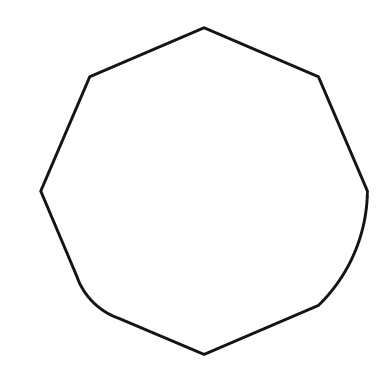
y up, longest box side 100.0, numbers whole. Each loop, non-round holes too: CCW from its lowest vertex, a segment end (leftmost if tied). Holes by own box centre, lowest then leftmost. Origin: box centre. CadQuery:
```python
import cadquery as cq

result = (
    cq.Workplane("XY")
    .moveTo(0.0, -50.0)
    .lineTo(35.0, -35.0)
    .threePointArc((46.0, -19.0), (50.0, 0.0))
    .lineTo(35.0, 35.0)
    .lineTo(0.0, 50.0)
    .lineTo(-35.0, 35.0)
    .lineTo(-50.0, 0.0)
    .lineTo(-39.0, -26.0)
    .threePointArc((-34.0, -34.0), (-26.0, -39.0))
    .close()
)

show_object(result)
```